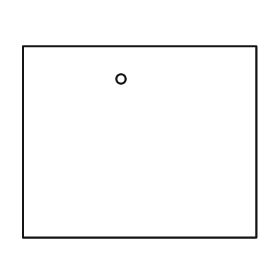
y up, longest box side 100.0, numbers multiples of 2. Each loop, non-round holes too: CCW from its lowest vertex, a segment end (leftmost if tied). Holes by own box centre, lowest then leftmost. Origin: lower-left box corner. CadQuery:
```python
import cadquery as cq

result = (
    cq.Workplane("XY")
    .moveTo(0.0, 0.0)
    .lineTo(100.0, 0.0)
    .lineTo(100.0, 82.0)
    .lineTo(0.0, 82.0)
    .close()
    .moveTo(42.0, 68.0)
    .circle(2.0)
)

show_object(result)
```